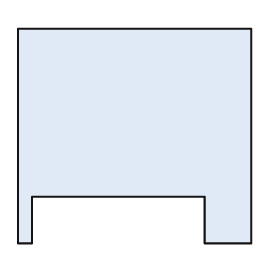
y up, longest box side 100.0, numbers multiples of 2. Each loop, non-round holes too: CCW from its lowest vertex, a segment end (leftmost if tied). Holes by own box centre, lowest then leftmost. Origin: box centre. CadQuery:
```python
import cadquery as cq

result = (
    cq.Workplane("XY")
    .moveTo(-50.0, -46.0)
    .lineTo(-44.0, -46.0)
    .lineTo(-44.0, -26.0)
    .lineTo(30.0, -26.0)
    .lineTo(30.0, -46.0)
    .lineTo(50.0, -46.0)
    .lineTo(50.0, 46.0)
    .lineTo(-50.0, 46.0)
    .close()
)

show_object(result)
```